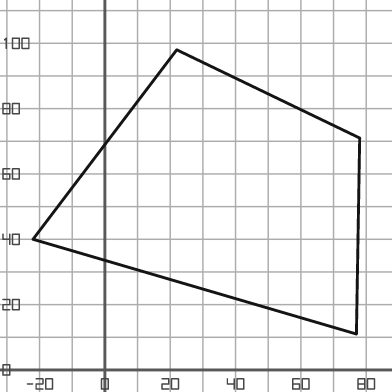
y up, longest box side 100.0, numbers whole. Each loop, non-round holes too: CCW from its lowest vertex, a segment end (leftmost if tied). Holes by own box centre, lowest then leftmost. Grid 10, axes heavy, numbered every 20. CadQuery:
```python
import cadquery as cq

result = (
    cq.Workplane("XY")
    .moveTo(77.0, 11.0)
    .lineTo(78.0, 71.0)
    .lineTo(22.0, 98.0)
    .lineTo(-22.0, 40.0)
    .close()
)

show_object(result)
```